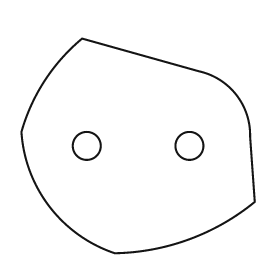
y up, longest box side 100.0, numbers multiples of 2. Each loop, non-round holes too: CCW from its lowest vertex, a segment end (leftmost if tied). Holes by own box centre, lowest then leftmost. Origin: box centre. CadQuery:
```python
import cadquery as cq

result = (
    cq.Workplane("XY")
    .moveTo(-10.0, -46.0)
    .threePointArc((22.0, -40.0), (50.0, -24.0))
    .lineTo(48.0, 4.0)
    .threePointArc((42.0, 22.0), (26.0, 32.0))
    .lineTo(-24.0, 46.0)
    .threePointArc((-40.0, 28.0), (-50.0, 6.0))
    .threePointArc((-38.0, -26.0), (-10.0, -46.0))
    .close()
    .moveTo(-22.0, 0.0)
    .circle(6.0)
    .moveTo(22.0, 0.0)
    .circle(6.0)
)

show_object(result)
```